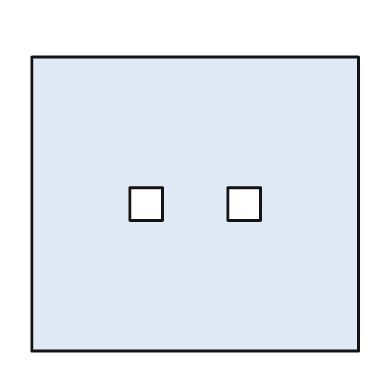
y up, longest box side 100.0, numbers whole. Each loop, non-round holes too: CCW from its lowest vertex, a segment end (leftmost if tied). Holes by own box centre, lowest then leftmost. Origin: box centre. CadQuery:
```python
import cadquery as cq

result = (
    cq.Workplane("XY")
    .moveTo(-50.0, -45.0)
    .lineTo(50.0, -45.0)
    .lineTo(50.0, 45.0)
    .lineTo(-50.0, 45.0)
    .close()
    .moveTo(-20.0, -5.0)
    .lineTo(-10.0, -5.0)
    .lineTo(-10.0, 5.0)
    .lineTo(-20.0, 5.0)
    .close()
    .moveTo(10.0, -5.0)
    .lineTo(20.0, -5.0)
    .lineTo(20.0, 5.0)
    .lineTo(10.0, 5.0)
    .close()
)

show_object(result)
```